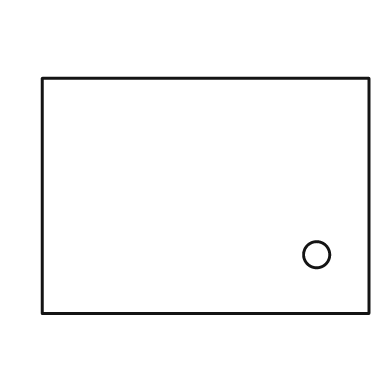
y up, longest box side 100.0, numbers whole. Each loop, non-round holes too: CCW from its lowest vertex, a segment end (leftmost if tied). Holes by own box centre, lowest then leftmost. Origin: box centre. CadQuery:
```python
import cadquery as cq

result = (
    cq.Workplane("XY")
    .moveTo(-50.0, -36.0)
    .lineTo(50.0, -36.0)
    .lineTo(50.0, 36.0)
    .lineTo(-50.0, 36.0)
    .close()
    .moveTo(34.0, -18.0)
    .circle(4.0)
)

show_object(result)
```